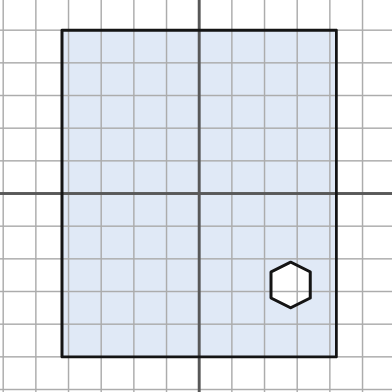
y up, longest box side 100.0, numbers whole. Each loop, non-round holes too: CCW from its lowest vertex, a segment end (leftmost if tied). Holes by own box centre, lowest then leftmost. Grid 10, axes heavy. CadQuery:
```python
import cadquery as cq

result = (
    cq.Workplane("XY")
    .moveTo(-42.0, -50.0)
    .lineTo(42.0, -50.0)
    .lineTo(42.0, 50.0)
    .lineTo(-42.0, 50.0)
    .close()
    .moveTo(28.0, -35.0)
    .lineTo(34.0, -32.0)
    .lineTo(34.0, -24.0)
    .lineTo(28.0, -21.0)
    .lineTo(22.0, -24.0)
    .lineTo(22.0, -32.0)
    .close()
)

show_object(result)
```